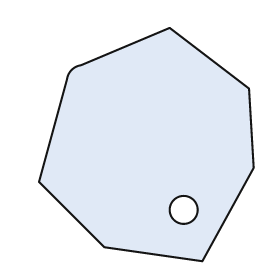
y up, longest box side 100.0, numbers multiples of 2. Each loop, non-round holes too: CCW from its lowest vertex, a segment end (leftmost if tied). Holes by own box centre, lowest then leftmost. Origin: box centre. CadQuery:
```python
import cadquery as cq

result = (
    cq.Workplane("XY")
    .moveTo(24.0, -50.0)
    .lineTo(46.0, -10.0)
    .lineTo(44.0, 24.0)
    .lineTo(10.0, 50.0)
    .lineTo(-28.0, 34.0)
    .threePointArc((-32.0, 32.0), (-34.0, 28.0))
    .lineTo(-46.0, -16.0)
    .lineTo(-18.0, -44.0)
    .close()
    .moveTo(16.0, -28.0)
    .circle(6.0)
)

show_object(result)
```